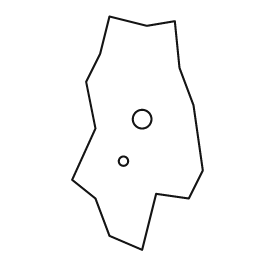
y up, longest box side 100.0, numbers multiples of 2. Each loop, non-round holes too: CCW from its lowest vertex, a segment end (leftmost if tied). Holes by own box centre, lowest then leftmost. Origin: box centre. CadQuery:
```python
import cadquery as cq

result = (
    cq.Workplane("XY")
    .moveTo(2.0, -50.0)
    .lineTo(8.0, -26.0)
    .lineTo(22.0, -28.0)
    .lineTo(28.0, -16.0)
    .lineTo(24.0, 12.0)
    .lineTo(18.0, 28.0)
    .lineTo(16.0, 48.0)
    .lineTo(4.0, 46.0)
    .lineTo(-12.0, 50.0)
    .lineTo(-16.0, 34.0)
    .lineTo(-22.0, 22.0)
    .lineTo(-18.0, 2.0)
    .lineTo(-28.0, -20.0)
    .lineTo(-18.0, -28.0)
    .lineTo(-12.0, -44.0)
    .close()
    .moveTo(-6.0, -12.0)
    .circle(2.0)
    .moveTo(2.0, 6.0)
    .circle(4.0)
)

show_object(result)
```